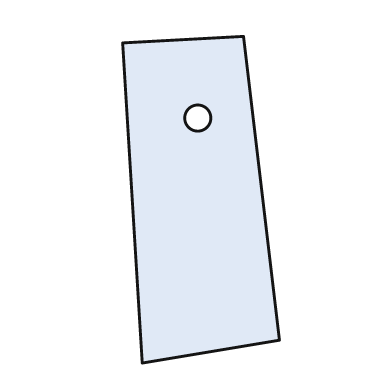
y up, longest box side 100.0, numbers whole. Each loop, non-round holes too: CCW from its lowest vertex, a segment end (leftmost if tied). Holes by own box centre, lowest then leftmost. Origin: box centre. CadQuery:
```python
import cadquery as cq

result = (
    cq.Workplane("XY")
    .moveTo(-18.0, -50.0)
    .lineTo(24.0, -43.0)
    .lineTo(13.0, 50.0)
    .lineTo(-24.0, 48.0)
    .close()
    .moveTo(-1.0, 25.0)
    .circle(4.0)
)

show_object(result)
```